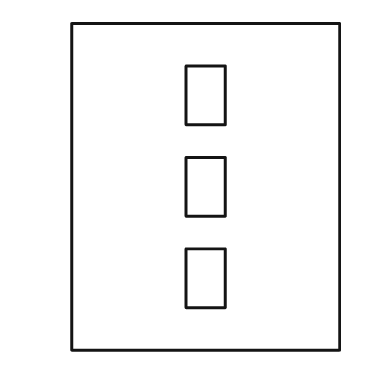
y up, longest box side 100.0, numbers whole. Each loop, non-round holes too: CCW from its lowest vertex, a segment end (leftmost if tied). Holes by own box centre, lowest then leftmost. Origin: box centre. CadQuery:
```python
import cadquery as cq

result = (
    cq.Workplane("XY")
    .moveTo(-41.0, -50.0)
    .lineTo(41.0, -50.0)
    .lineTo(41.0, 50.0)
    .lineTo(-41.0, 50.0)
    .close()
    .moveTo(-6.0, -37.0)
    .lineTo(6.0, -37.0)
    .lineTo(6.0, -19.0)
    .lineTo(-6.0, -19.0)
    .close()
    .moveTo(-6.0, -9.0)
    .lineTo(6.0, -9.0)
    .lineTo(6.0, 9.0)
    .lineTo(-6.0, 9.0)
    .close()
    .moveTo(-6.0, 19.0)
    .lineTo(6.0, 19.0)
    .lineTo(6.0, 37.0)
    .lineTo(-6.0, 37.0)
    .close()
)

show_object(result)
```